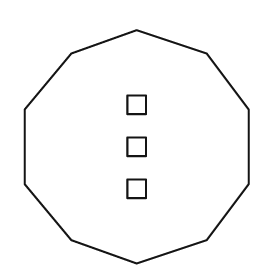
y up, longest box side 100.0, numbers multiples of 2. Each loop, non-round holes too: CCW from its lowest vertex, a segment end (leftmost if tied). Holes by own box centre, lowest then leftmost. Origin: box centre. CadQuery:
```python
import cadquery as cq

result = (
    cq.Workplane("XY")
    .moveTo(0.0, -50.0)
    .lineTo(30.0, -40.0)
    .lineTo(48.0, -16.0)
    .lineTo(48.0, 16.0)
    .lineTo(30.0, 40.0)
    .lineTo(0.0, 50.0)
    .lineTo(-28.0, 40.0)
    .lineTo(-48.0, 16.0)
    .lineTo(-48.0, -16.0)
    .lineTo(-28.0, -40.0)
    .close()
    .moveTo(-4.0, -22.0)
    .lineTo(4.0, -22.0)
    .lineTo(4.0, -14.0)
    .lineTo(-4.0, -14.0)
    .close()
    .moveTo(-4.0, -4.0)
    .lineTo(4.0, -4.0)
    .lineTo(4.0, 4.0)
    .lineTo(-4.0, 4.0)
    .close()
    .moveTo(-4.0, 14.0)
    .lineTo(4.0, 14.0)
    .lineTo(4.0, 22.0)
    .lineTo(-4.0, 22.0)
    .close()
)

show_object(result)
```